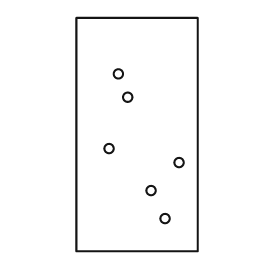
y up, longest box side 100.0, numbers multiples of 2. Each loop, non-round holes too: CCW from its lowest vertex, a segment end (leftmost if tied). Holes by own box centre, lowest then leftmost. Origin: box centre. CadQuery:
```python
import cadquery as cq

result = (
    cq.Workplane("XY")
    .moveTo(-26.0, -50.0)
    .lineTo(26.0, -50.0)
    .lineTo(26.0, 50.0)
    .lineTo(-26.0, 50.0)
    .close()
    .moveTo(12.0, -36.0)
    .circle(2.0)
    .moveTo(6.0, -24.0)
    .circle(2.0)
    .moveTo(18.0, -12.0)
    .circle(2.0)
    .moveTo(-12.0, -6.0)
    .circle(2.0)
    .moveTo(-4.0, 16.0)
    .circle(2.0)
    .moveTo(-8.0, 26.0)
    .circle(2.0)
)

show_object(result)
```